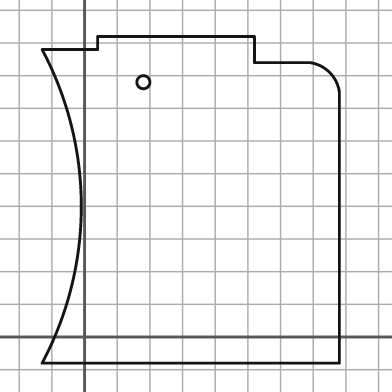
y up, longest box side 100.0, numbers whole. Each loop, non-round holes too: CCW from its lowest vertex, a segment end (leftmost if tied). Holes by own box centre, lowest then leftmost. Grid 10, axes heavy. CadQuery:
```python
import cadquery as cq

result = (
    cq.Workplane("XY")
    .moveTo(-13.0, -8.0)
    .lineTo(78.0, -8.0)
    .lineTo(78.0, 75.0)
    .threePointArc((75.0, 81.0), (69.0, 84.0))
    .lineTo(52.0, 84.0)
    .lineTo(52.0, 92.0)
    .lineTo(4.0, 92.0)
    .lineTo(4.0, 88.0)
    .lineTo(-13.0, 88.0)
    .threePointArc((-1.0, 40.0), (-13.0, -8.0))
    .close()
    .moveTo(18.0, 78.0)
    .circle(2.0)
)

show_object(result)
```